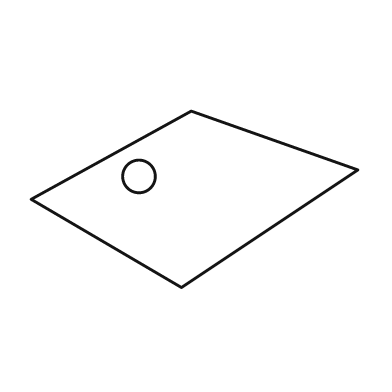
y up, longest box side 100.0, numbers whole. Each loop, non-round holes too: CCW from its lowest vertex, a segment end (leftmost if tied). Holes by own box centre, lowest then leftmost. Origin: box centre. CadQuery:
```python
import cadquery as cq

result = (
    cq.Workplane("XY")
    .moveTo(-4.0, -27.0)
    .lineTo(50.0, 9.0)
    .lineTo(-1.0, 27.0)
    .lineTo(-50.0, 0.0)
    .close()
    .moveTo(-17.0, 7.0)
    .circle(5.0)
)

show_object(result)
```